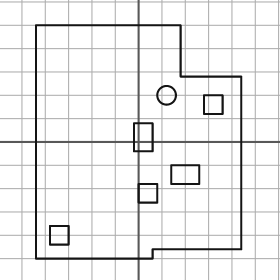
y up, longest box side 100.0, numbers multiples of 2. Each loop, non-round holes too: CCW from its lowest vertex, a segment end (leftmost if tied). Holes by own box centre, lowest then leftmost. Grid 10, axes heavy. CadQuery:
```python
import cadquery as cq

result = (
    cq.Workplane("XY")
    .moveTo(-44.0, -50.0)
    .lineTo(6.0, -50.0)
    .lineTo(6.0, -46.0)
    .lineTo(44.0, -46.0)
    .lineTo(44.0, 28.0)
    .lineTo(18.0, 28.0)
    .lineTo(18.0, 50.0)
    .lineTo(-44.0, 50.0)
    .close()
    .moveTo(-38.0, -44.0)
    .lineTo(-30.0, -44.0)
    .lineTo(-30.0, -36.0)
    .lineTo(-38.0, -36.0)
    .close()
    .moveTo(0.0, -26.0)
    .lineTo(8.0, -26.0)
    .lineTo(8.0, -18.0)
    .lineTo(0.0, -18.0)
    .close()
    .moveTo(14.0, -18.0)
    .lineTo(26.0, -18.0)
    .lineTo(26.0, -10.0)
    .lineTo(14.0, -10.0)
    .close()
    .moveTo(-2.0, -4.0)
    .lineTo(6.0, -4.0)
    .lineTo(6.0, 8.0)
    .lineTo(-2.0, 8.0)
    .close()
    .moveTo(28.0, 12.0)
    .lineTo(36.0, 12.0)
    .lineTo(36.0, 20.0)
    .lineTo(28.0, 20.0)
    .close()
    .moveTo(12.0, 20.0)
    .circle(4.0)
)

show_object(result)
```